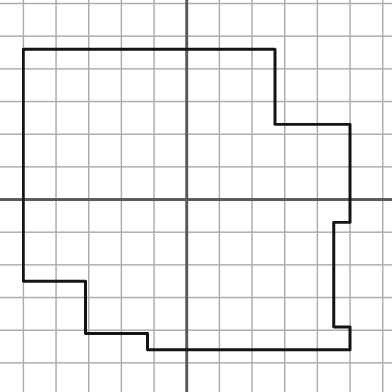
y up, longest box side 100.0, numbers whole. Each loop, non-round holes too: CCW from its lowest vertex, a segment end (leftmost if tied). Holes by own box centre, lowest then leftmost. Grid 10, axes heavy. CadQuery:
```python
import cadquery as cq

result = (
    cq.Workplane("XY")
    .moveTo(-12.0, -46.0)
    .lineTo(50.0, -46.0)
    .lineTo(50.0, -39.0)
    .lineTo(45.0, -39.0)
    .lineTo(45.0, -7.0)
    .lineTo(50.0, -7.0)
    .lineTo(50.0, 23.0)
    .lineTo(27.0, 23.0)
    .lineTo(27.0, 46.0)
    .lineTo(-50.0, 46.0)
    .lineTo(-50.0, -25.0)
    .lineTo(-31.0, -25.0)
    .lineTo(-31.0, -41.0)
    .lineTo(-12.0, -41.0)
    .close()
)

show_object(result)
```